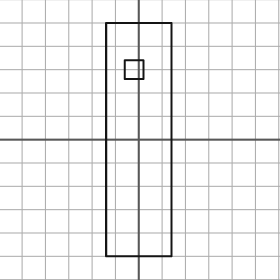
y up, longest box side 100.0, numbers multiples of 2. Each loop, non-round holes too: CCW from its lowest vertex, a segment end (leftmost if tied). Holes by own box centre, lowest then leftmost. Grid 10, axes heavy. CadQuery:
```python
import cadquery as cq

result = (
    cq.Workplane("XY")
    .moveTo(-14.0, -50.0)
    .lineTo(14.0, -50.0)
    .lineTo(14.0, 50.0)
    .lineTo(-14.0, 50.0)
    .close()
    .moveTo(-6.0, 26.0)
    .lineTo(2.0, 26.0)
    .lineTo(2.0, 34.0)
    .lineTo(-6.0, 34.0)
    .close()
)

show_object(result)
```